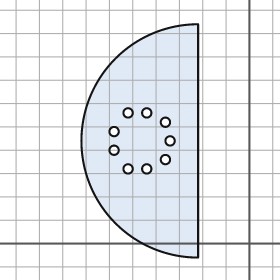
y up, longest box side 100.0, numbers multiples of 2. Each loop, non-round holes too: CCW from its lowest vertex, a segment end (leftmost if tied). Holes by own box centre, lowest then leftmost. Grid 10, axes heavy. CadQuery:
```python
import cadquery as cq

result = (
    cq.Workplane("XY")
    .moveTo(-22.0, -6.0)
    .lineTo(-22.0, 94.0)
    .threePointArc((-72.0, 44.0), (-22.0, -6.0))
    .close()
    .moveTo(-52.0, 32.0)
    .circle(2.0)
    .moveTo(-44.0, 32.0)
    .circle(2.0)
    .moveTo(-36.0, 36.0)
    .circle(2.0)
    .moveTo(-58.0, 40.0)
    .circle(2.0)
    .moveTo(-34.0, 44.0)
    .circle(2.0)
    .moveTo(-58.0, 48.0)
    .circle(2.0)
    .moveTo(-36.0, 52.0)
    .circle(2.0)
    .moveTo(-52.0, 56.0)
    .circle(2.0)
    .moveTo(-44.0, 56.0)
    .circle(2.0)
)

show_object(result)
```